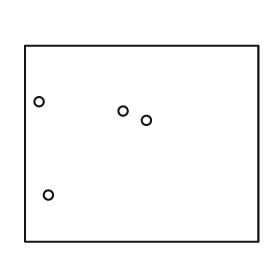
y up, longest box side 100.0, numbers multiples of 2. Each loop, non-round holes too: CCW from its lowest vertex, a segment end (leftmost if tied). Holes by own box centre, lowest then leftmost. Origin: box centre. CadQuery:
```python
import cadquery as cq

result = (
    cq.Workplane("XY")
    .moveTo(-50.0, -42.0)
    .lineTo(50.0, -42.0)
    .lineTo(50.0, 42.0)
    .lineTo(-50.0, 42.0)
    .close()
    .moveTo(-40.0, -22.0)
    .circle(2.0)
    .moveTo(2.0, 10.0)
    .circle(2.0)
    .moveTo(-8.0, 14.0)
    .circle(2.0)
    .moveTo(-44.0, 18.0)
    .circle(2.0)
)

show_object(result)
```